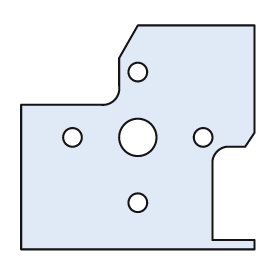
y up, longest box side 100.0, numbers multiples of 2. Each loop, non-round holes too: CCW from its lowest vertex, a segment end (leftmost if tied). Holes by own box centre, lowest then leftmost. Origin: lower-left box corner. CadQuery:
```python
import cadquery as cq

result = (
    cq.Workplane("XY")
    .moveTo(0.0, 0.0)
    .lineTo(100.0, 0.0)
    .lineTo(100.0, 4.0)
    .lineTo(82.0, 4.0)
    .lineTo(82.0, 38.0)
    .threePointArc((84.0, 42.0), (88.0, 44.0))
    .lineTo(96.0, 44.0)
    .lineTo(100.0, 50.0)
    .lineTo(100.0, 96.0)
    .lineTo(50.0, 96.0)
    .lineTo(42.0, 82.0)
    .lineTo(42.0, 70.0)
    .threePointArc((40.0, 64.0), (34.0, 62.0))
    .lineTo(0.0, 62.0)
    .close()
    .moveTo(50.0, 20.0)
    .circle(4.0)
    .moveTo(22.0, 48.0)
    .circle(4.0)
    .moveTo(50.0, 48.0)
    .circle(8.0)
    .moveTo(78.0, 48.0)
    .circle(4.0)
    .moveTo(50.0, 76.0)
    .circle(4.0)
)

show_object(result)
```